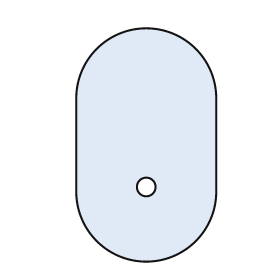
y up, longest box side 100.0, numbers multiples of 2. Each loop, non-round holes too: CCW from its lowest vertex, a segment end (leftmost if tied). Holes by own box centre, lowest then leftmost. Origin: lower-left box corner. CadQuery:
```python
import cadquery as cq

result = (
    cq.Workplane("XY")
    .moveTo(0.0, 30.0)
    .threePointArc((30.0, 0.0), (60.0, 30.0))
    .lineTo(60.0, 70.0)
    .threePointArc((30.0, 100.0), (0.0, 70.0))
    .close()
    .moveTo(30.0, 32.0)
    .circle(4.0)
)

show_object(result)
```